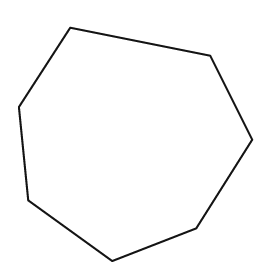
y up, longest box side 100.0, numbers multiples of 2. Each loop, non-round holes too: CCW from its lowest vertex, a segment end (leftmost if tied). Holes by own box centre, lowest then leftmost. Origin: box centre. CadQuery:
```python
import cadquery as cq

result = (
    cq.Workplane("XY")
    .moveTo(-10.0, -50.0)
    .lineTo(26.0, -36.0)
    .lineTo(50.0, 2.0)
    .lineTo(32.0, 38.0)
    .lineTo(-28.0, 50.0)
    .lineTo(-50.0, 16.0)
    .lineTo(-46.0, -24.0)
    .close()
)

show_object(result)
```